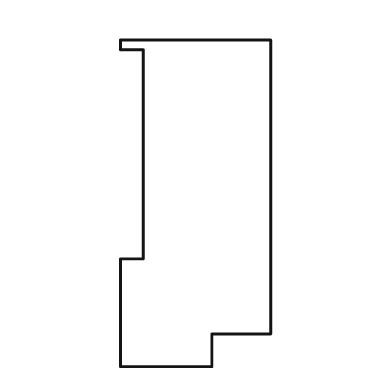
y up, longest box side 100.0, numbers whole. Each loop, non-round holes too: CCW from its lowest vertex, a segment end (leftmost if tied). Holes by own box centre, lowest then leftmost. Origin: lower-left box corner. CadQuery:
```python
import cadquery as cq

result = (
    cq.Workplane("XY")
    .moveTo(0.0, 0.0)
    .lineTo(28.0, 0.0)
    .lineTo(28.0, 10.0)
    .lineTo(46.0, 10.0)
    .lineTo(46.0, 100.0)
    .lineTo(0.0, 100.0)
    .lineTo(0.0, 97.0)
    .lineTo(7.0, 97.0)
    .lineTo(7.0, 33.0)
    .lineTo(0.0, 33.0)
    .close()
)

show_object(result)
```